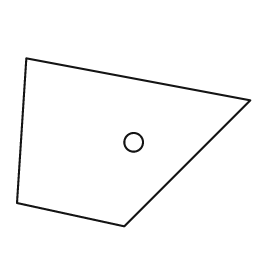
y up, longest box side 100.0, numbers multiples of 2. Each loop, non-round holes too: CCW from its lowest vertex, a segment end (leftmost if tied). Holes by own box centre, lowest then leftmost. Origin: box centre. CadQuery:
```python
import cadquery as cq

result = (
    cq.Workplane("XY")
    .moveTo(-4.0, -36.0)
    .lineTo(50.0, 18.0)
    .lineTo(-46.0, 36.0)
    .lineTo(-50.0, -26.0)
    .close()
    .moveTo(0.0, 0.0)
    .circle(4.0)
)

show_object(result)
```